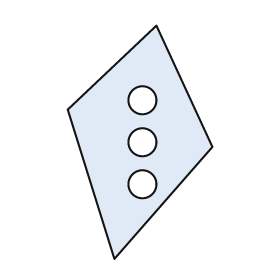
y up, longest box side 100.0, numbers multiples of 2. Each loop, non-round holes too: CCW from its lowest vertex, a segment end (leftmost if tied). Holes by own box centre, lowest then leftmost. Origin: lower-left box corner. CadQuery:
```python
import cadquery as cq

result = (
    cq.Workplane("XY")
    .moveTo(20.0, 0.0)
    .lineTo(62.0, 48.0)
    .lineTo(38.0, 100.0)
    .lineTo(0.0, 64.0)
    .close()
    .moveTo(32.0, 32.0)
    .circle(6.0)
    .moveTo(32.0, 50.0)
    .circle(6.0)
    .moveTo(32.0, 68.0)
    .circle(6.0)
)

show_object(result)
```